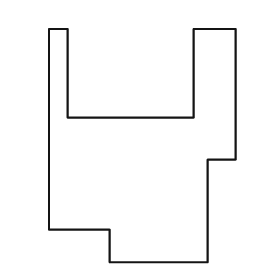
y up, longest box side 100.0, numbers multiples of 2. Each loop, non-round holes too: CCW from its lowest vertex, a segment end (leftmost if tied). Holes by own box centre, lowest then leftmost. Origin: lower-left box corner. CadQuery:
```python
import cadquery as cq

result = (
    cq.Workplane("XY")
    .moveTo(26.0, 0.0)
    .lineTo(68.0, 0.0)
    .lineTo(68.0, 44.0)
    .lineTo(80.0, 44.0)
    .lineTo(80.0, 100.0)
    .lineTo(62.0, 100.0)
    .lineTo(62.0, 62.0)
    .lineTo(8.0, 62.0)
    .lineTo(8.0, 100.0)
    .lineTo(0.0, 100.0)
    .lineTo(0.0, 14.0)
    .lineTo(26.0, 14.0)
    .close()
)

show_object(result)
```